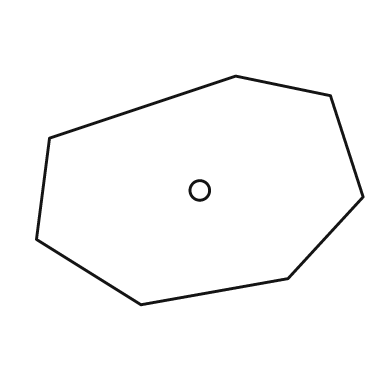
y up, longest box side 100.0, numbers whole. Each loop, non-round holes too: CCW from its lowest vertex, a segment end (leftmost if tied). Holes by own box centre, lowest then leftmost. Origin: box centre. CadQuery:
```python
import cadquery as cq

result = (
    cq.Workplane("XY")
    .moveTo(-18.0, -35.0)
    .lineTo(27.0, -27.0)
    .lineTo(50.0, -2.0)
    .lineTo(40.0, 29.0)
    .lineTo(11.0, 35.0)
    .lineTo(-46.0, 16.0)
    .lineTo(-50.0, -15.0)
    .close()
    .moveTo(0.0, 0.0)
    .circle(3.0)
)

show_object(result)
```